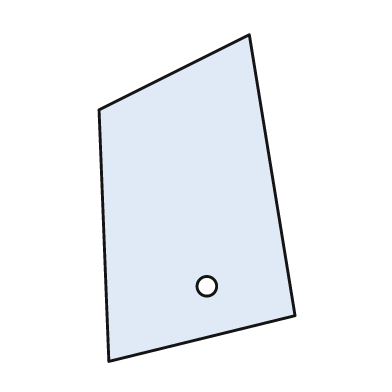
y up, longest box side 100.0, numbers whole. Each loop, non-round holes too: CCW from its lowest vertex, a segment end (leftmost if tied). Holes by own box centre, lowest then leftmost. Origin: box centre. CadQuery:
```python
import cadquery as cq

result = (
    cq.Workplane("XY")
    .moveTo(-27.0, -50.0)
    .lineTo(30.0, -36.0)
    .lineTo(16.0, 50.0)
    .lineTo(-30.0, 27.0)
    .close()
    .moveTo(3.0, -27.0)
    .circle(3.0)
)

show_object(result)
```